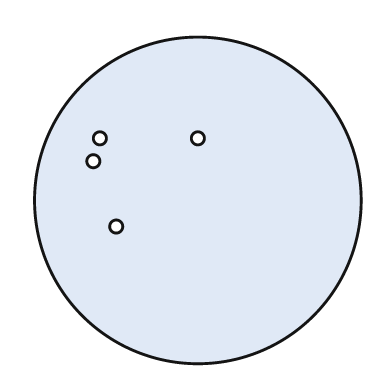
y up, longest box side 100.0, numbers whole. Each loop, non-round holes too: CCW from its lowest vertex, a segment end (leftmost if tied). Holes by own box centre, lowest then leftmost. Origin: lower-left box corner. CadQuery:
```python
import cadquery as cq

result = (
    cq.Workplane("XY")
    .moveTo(50.0, 50.0)
    .circle(50.0)
    .moveTo(25.0, 42.0)
    .circle(2.0)
    .moveTo(18.0, 62.0)
    .circle(2.0)
    .moveTo(20.0, 69.0)
    .circle(2.0)
    .moveTo(50.0, 69.0)
    .circle(2.0)
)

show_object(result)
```